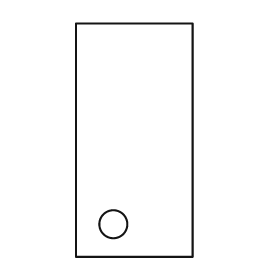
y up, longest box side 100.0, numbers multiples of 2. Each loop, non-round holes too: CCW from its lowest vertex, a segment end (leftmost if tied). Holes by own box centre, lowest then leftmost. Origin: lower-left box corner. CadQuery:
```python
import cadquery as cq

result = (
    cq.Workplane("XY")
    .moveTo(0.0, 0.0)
    .lineTo(50.0, 0.0)
    .lineTo(50.0, 100.0)
    .lineTo(0.0, 100.0)
    .close()
    .moveTo(16.0, 14.0)
    .circle(6.0)
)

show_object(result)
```